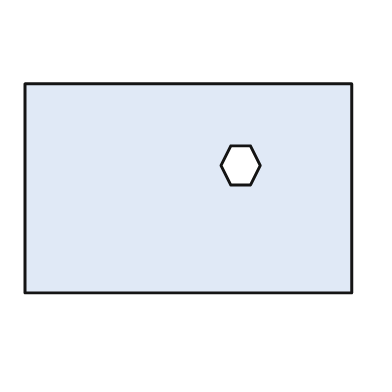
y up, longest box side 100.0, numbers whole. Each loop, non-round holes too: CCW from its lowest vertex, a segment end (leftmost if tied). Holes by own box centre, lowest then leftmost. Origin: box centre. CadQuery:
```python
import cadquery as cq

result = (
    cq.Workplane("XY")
    .moveTo(-50.0, -32.0)
    .lineTo(50.0, -32.0)
    .lineTo(50.0, 32.0)
    .lineTo(-50.0, 32.0)
    .close()
    .moveTo(13.0, 1.0)
    .lineTo(19.0, 1.0)
    .lineTo(22.0, 7.0)
    .lineTo(19.0, 13.0)
    .lineTo(13.0, 13.0)
    .lineTo(10.0, 7.0)
    .close()
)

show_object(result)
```